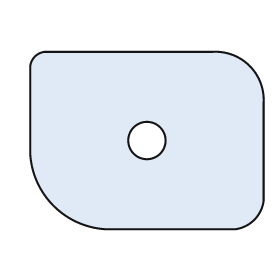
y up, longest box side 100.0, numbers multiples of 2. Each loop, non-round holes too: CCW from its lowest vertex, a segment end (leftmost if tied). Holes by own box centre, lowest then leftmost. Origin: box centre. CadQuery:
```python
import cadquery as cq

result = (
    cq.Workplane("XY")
    .moveTo(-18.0, -38.0)
    .lineTo(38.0, -38.0)
    .threePointArc((46.0, -34.0), (50.0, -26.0))
    .lineTo(50.0, 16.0)
    .threePointArc((44.0, 32.0), (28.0, 38.0))
    .lineTo(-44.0, 38.0)
    .threePointArc((-48.0, 36.0), (-50.0, 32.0))
    .lineTo(-50.0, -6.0)
    .threePointArc((-40.0, -28.0), (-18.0, -38.0))
    .close()
    .moveTo(0.0, 0.0)
    .circle(8.0)
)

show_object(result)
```